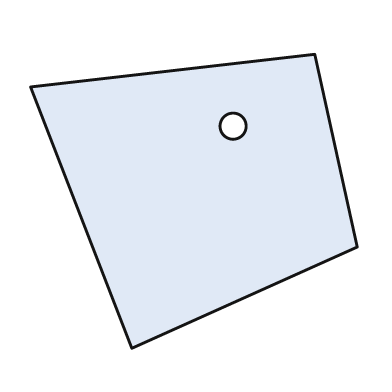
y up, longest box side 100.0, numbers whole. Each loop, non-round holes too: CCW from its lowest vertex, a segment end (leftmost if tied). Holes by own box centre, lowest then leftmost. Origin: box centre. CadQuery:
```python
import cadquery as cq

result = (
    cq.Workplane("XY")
    .moveTo(-19.0, -45.0)
    .lineTo(50.0, -14.0)
    .lineTo(37.0, 45.0)
    .lineTo(-50.0, 35.0)
    .close()
    .moveTo(12.0, 23.0)
    .circle(4.0)
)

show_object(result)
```